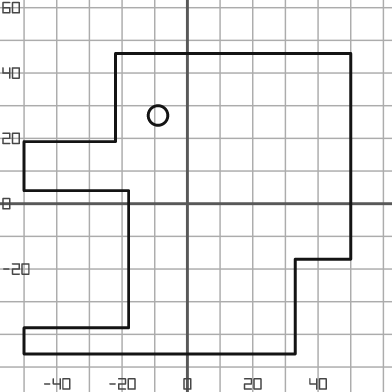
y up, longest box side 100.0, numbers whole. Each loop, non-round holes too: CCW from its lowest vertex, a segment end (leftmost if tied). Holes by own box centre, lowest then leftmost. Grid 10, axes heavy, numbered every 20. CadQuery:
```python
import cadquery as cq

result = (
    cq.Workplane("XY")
    .moveTo(-50.0, -46.0)
    .lineTo(33.0, -46.0)
    .lineTo(33.0, -17.0)
    .lineTo(50.0, -17.0)
    .lineTo(50.0, 46.0)
    .lineTo(-22.0, 46.0)
    .lineTo(-22.0, 19.0)
    .lineTo(-50.0, 19.0)
    .lineTo(-50.0, 4.0)
    .lineTo(-18.0, 4.0)
    .lineTo(-18.0, -38.0)
    .lineTo(-50.0, -38.0)
    .close()
    .moveTo(-9.0, 27.0)
    .circle(3.0)
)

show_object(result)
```